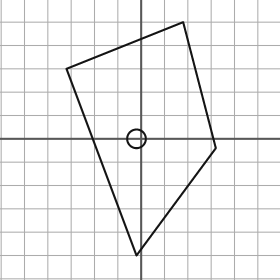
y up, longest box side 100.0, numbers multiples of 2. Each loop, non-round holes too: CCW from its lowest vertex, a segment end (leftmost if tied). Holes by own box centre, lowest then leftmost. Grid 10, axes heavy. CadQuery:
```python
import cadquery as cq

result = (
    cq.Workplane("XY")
    .moveTo(-2.0, -50.0)
    .lineTo(32.0, -4.0)
    .lineTo(18.0, 50.0)
    .lineTo(-32.0, 30.0)
    .close()
    .moveTo(-2.0, 0.0)
    .circle(4.0)
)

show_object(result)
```